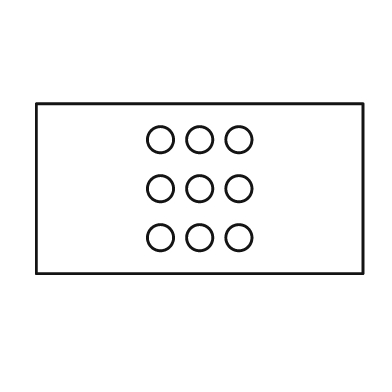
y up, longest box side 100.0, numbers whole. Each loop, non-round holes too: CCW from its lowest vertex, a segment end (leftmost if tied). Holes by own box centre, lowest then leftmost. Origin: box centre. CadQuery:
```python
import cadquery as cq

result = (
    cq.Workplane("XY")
    .moveTo(-50.0, -26.0)
    .lineTo(50.0, -26.0)
    .lineTo(50.0, 26.0)
    .lineTo(-50.0, 26.0)
    .close()
    .moveTo(-12.0, -15.0)
    .circle(4.0)
    .moveTo(0.0, -15.0)
    .circle(4.0)
    .moveTo(12.0, -15.0)
    .circle(4.0)
    .moveTo(-12.0, 0.0)
    .circle(4.0)
    .moveTo(0.0, 0.0)
    .circle(4.0)
    .moveTo(12.0, 0.0)
    .circle(4.0)
    .moveTo(-12.0, 15.0)
    .circle(4.0)
    .moveTo(0.0, 15.0)
    .circle(4.0)
    .moveTo(12.0, 15.0)
    .circle(4.0)
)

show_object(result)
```